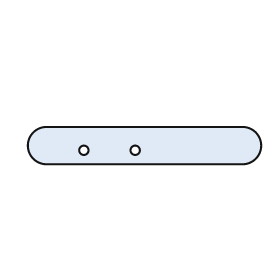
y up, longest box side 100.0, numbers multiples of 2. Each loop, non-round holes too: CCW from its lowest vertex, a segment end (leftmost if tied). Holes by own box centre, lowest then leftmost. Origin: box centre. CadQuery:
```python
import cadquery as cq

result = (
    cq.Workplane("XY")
    .moveTo(-42.0, -8.0)
    .lineTo(42.0, -8.0)
    .threePointArc((50.0, 0.0), (42.0, 8.0))
    .lineTo(-42.0, 8.0)
    .threePointArc((-50.0, 0.0), (-42.0, -8.0))
    .close()
    .moveTo(-26.0, -2.0)
    .circle(2.0)
    .moveTo(-4.0, -2.0)
    .circle(2.0)
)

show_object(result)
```